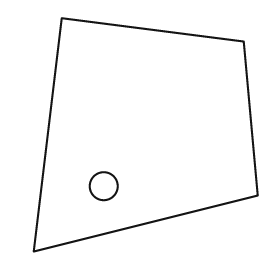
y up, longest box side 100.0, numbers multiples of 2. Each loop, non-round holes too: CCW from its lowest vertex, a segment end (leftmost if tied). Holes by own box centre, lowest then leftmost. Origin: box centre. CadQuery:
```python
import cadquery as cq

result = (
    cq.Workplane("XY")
    .moveTo(-48.0, -50.0)
    .lineTo(48.0, -26.0)
    .lineTo(42.0, 40.0)
    .lineTo(-36.0, 50.0)
    .close()
    .moveTo(-18.0, -22.0)
    .circle(6.0)
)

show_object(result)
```